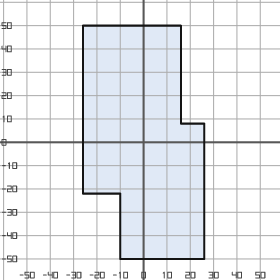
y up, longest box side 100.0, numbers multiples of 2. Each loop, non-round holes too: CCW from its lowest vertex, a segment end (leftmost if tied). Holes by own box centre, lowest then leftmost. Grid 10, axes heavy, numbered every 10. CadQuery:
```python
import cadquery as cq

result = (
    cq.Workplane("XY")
    .moveTo(-10.0, -50.0)
    .lineTo(26.0, -50.0)
    .lineTo(26.0, 8.0)
    .lineTo(16.0, 8.0)
    .lineTo(16.0, 50.0)
    .lineTo(-26.0, 50.0)
    .lineTo(-26.0, -22.0)
    .lineTo(-10.0, -22.0)
    .close()
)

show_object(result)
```